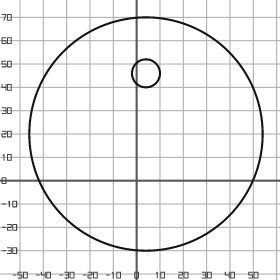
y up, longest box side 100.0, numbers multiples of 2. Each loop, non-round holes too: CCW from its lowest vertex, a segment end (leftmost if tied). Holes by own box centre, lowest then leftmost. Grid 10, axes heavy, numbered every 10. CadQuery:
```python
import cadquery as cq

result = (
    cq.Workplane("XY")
    .moveTo(4.0, 20.0)
    .circle(50.0)
    .moveTo(4.0, 46.0)
    .circle(6.0)
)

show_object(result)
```